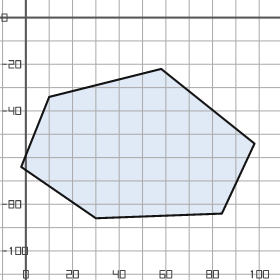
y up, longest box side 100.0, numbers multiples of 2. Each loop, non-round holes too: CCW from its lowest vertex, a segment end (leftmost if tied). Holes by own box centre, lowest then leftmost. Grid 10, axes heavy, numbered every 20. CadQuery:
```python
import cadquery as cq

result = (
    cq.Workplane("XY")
    .moveTo(30.0, -86.0)
    .lineTo(84.0, -84.0)
    .lineTo(98.0, -54.0)
    .lineTo(58.0, -22.0)
    .lineTo(10.0, -34.0)
    .lineTo(-2.0, -64.0)
    .close()
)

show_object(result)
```